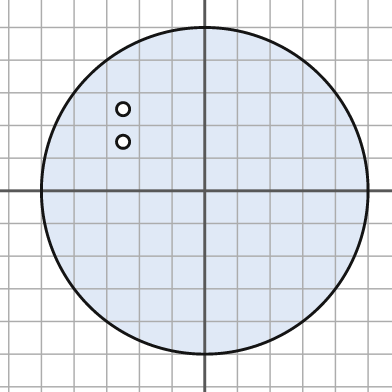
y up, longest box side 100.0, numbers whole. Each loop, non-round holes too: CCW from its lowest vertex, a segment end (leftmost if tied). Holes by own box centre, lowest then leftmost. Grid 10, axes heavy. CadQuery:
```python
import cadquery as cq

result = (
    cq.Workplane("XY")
    .moveTo(0.0, 0.0)
    .circle(50.0)
    .moveTo(-25.0, 15.0)
    .circle(2.0)
    .moveTo(-25.0, 25.0)
    .circle(2.0)
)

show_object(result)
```